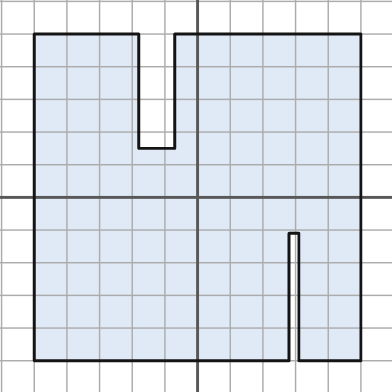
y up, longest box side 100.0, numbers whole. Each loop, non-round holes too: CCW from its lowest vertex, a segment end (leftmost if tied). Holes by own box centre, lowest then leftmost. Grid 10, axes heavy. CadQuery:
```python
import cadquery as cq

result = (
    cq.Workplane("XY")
    .moveTo(-50.0, -50.0)
    .lineTo(28.0, -50.0)
    .lineTo(28.0, -11.0)
    .lineTo(31.0, -11.0)
    .lineTo(31.0, -50.0)
    .lineTo(50.0, -50.0)
    .lineTo(50.0, 50.0)
    .lineTo(-7.0, 50.0)
    .lineTo(-7.0, 15.0)
    .lineTo(-18.0, 15.0)
    .lineTo(-18.0, 50.0)
    .lineTo(-50.0, 50.0)
    .close()
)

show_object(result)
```